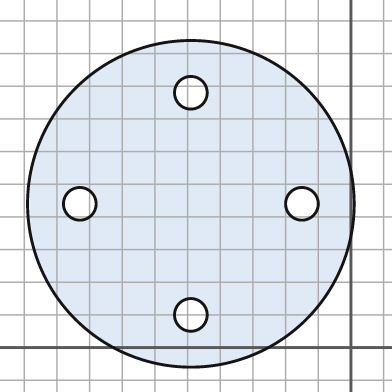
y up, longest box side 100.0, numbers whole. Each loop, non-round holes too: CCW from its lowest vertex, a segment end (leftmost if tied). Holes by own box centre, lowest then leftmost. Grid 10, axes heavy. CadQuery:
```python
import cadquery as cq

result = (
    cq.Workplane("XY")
    .moveTo(-49.0, 44.0)
    .circle(50.0)
    .moveTo(-49.0, 10.0)
    .circle(5.0)
    .moveTo(-83.0, 44.0)
    .circle(5.0)
    .moveTo(-15.0, 44.0)
    .circle(5.0)
    .moveTo(-49.0, 78.0)
    .circle(5.0)
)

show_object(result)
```